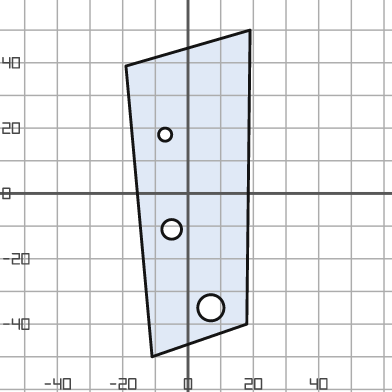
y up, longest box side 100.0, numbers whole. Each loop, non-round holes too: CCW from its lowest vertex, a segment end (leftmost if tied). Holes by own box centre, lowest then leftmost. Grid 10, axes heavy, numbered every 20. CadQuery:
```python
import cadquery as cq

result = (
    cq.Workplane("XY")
    .moveTo(-11.0, -50.0)
    .lineTo(18.0, -40.0)
    .lineTo(19.0, 50.0)
    .lineTo(-19.0, 39.0)
    .close()
    .moveTo(7.0, -35.0)
    .circle(4.0)
    .moveTo(-5.0, -11.0)
    .circle(3.0)
    .moveTo(-7.0, 18.0)
    .circle(2.0)
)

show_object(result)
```